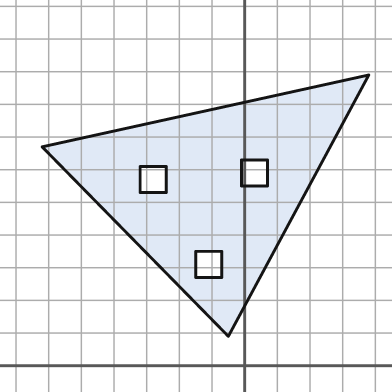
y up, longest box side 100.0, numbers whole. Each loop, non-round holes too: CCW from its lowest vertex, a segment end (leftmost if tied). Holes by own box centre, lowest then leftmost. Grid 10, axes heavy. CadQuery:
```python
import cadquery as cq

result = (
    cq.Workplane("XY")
    .moveTo(-5.0, 9.0)
    .lineTo(38.0, 89.0)
    .lineTo(-62.0, 67.0)
    .close()
    .moveTo(-15.0, 27.0)
    .lineTo(-7.0, 27.0)
    .lineTo(-7.0, 35.0)
    .lineTo(-15.0, 35.0)
    .close()
    .moveTo(-32.0, 53.0)
    .lineTo(-24.0, 53.0)
    .lineTo(-24.0, 61.0)
    .lineTo(-32.0, 61.0)
    .close()
    .moveTo(-1.0, 55.0)
    .lineTo(7.0, 55.0)
    .lineTo(7.0, 63.0)
    .lineTo(-1.0, 63.0)
    .close()
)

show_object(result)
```